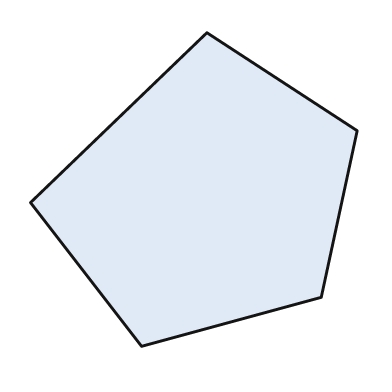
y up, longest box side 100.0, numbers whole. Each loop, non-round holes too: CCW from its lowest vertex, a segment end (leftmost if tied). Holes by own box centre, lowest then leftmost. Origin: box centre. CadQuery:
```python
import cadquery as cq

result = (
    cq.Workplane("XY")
    .moveTo(-16.0, -48.0)
    .lineTo(39.0, -33.0)
    .lineTo(50.0, 18.0)
    .lineTo(4.0, 48.0)
    .lineTo(-50.0, -4.0)
    .close()
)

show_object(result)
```